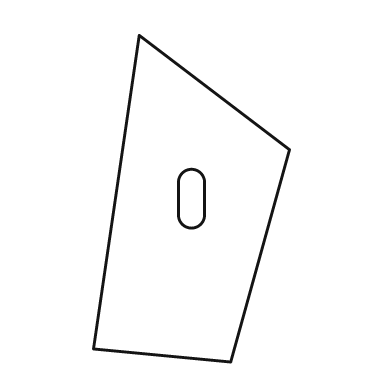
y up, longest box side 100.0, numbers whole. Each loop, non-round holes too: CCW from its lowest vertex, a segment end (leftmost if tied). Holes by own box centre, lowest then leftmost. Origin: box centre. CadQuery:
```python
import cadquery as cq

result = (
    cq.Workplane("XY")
    .moveTo(12.0, -50.0)
    .lineTo(30.0, 15.0)
    .lineTo(-16.0, 50.0)
    .lineTo(-30.0, -46.0)
    .close()
    .moveTo(-4.0, -5.0)
    .threePointArc((0.0, -9.0), (4.0, -5.0))
    .lineTo(4.0, 5.0)
    .threePointArc((0.0, 9.0), (-4.0, 5.0))
    .close()
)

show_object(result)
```